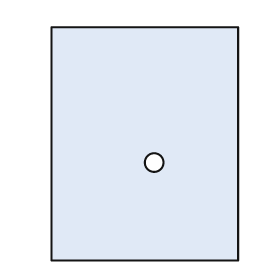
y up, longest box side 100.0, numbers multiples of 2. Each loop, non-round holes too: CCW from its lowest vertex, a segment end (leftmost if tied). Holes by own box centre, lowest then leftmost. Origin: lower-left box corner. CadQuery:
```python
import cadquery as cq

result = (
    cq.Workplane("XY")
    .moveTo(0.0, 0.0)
    .lineTo(80.0, 0.0)
    .lineTo(80.0, 100.0)
    .lineTo(0.0, 100.0)
    .close()
    .moveTo(44.0, 42.0)
    .circle(4.0)
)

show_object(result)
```